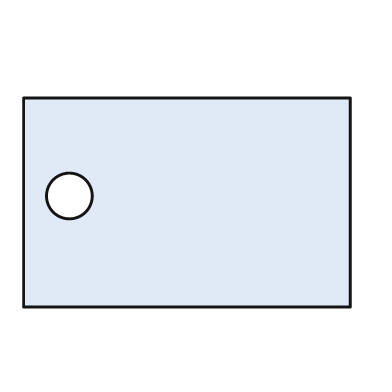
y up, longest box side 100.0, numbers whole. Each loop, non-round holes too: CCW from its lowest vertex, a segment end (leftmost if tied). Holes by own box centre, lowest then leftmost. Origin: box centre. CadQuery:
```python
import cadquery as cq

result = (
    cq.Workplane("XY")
    .moveTo(-50.0, -32.0)
    .lineTo(50.0, -32.0)
    .lineTo(50.0, 32.0)
    .lineTo(-50.0, 32.0)
    .close()
    .moveTo(-36.0, 2.0)
    .circle(7.0)
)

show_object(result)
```